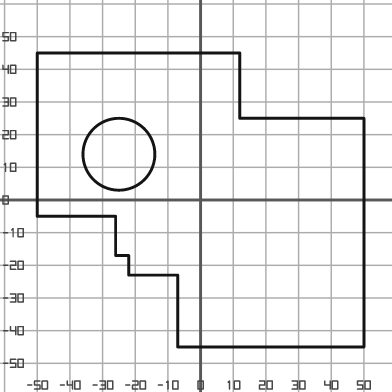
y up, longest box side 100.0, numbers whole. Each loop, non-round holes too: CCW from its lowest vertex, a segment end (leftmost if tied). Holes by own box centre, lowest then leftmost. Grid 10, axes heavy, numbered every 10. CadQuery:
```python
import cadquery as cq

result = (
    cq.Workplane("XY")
    .moveTo(-7.0, -45.0)
    .lineTo(50.0, -45.0)
    .lineTo(50.0, 25.0)
    .lineTo(12.0, 25.0)
    .lineTo(12.0, 45.0)
    .lineTo(-50.0, 45.0)
    .lineTo(-50.0, -5.0)
    .lineTo(-26.0, -5.0)
    .lineTo(-26.0, -17.0)
    .lineTo(-22.0, -17.0)
    .lineTo(-22.0, -23.0)
    .lineTo(-7.0, -23.0)
    .close()
    .moveTo(-25.0, 14.0)
    .circle(11.0)
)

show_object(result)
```